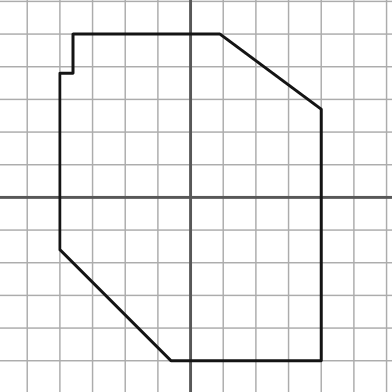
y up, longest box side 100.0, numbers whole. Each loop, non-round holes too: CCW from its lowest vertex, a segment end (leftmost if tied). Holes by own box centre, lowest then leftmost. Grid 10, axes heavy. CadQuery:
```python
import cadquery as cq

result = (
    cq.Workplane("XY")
    .moveTo(-6.0, -50.0)
    .lineTo(40.0, -50.0)
    .lineTo(40.0, 27.0)
    .lineTo(9.0, 50.0)
    .lineTo(-36.0, 50.0)
    .lineTo(-36.0, 38.0)
    .lineTo(-40.0, 38.0)
    .lineTo(-40.0, -16.0)
    .close()
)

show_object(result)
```